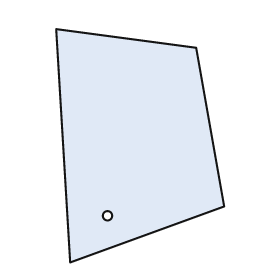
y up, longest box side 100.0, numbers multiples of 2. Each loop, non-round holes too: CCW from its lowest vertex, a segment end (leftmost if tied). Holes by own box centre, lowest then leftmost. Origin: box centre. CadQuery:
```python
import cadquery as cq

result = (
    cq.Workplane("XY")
    .moveTo(-30.0, -50.0)
    .lineTo(36.0, -26.0)
    .lineTo(24.0, 42.0)
    .lineTo(-36.0, 50.0)
    .close()
    .moveTo(-14.0, -30.0)
    .circle(2.0)
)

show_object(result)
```